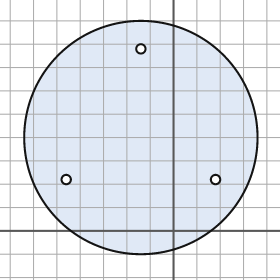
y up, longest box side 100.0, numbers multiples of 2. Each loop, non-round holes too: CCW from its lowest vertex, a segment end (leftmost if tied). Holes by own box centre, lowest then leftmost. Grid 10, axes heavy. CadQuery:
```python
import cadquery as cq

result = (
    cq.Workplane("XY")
    .moveTo(-14.0, 40.0)
    .circle(50.0)
    .moveTo(-46.0, 22.0)
    .circle(2.0)
    .moveTo(18.0, 22.0)
    .circle(2.0)
    .moveTo(-14.0, 78.0)
    .circle(2.0)
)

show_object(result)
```